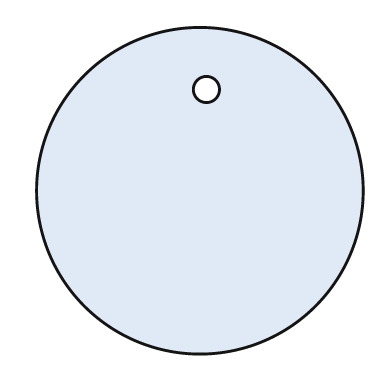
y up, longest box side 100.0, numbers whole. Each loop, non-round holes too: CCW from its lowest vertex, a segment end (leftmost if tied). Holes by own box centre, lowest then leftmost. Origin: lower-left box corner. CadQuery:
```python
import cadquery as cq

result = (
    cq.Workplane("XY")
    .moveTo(50.0, 50.0)
    .circle(50.0)
    .moveTo(52.0, 81.0)
    .circle(4.0)
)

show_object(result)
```